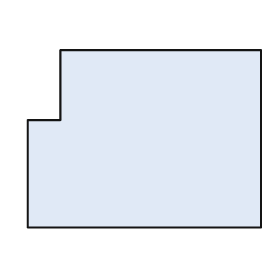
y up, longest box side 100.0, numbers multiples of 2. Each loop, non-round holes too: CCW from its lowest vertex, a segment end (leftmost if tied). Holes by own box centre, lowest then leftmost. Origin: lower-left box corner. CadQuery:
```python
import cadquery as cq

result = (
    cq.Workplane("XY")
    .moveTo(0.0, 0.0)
    .lineTo(100.0, 0.0)
    .lineTo(100.0, 76.0)
    .lineTo(14.0, 76.0)
    .lineTo(14.0, 46.0)
    .lineTo(0.0, 46.0)
    .close()
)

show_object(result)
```